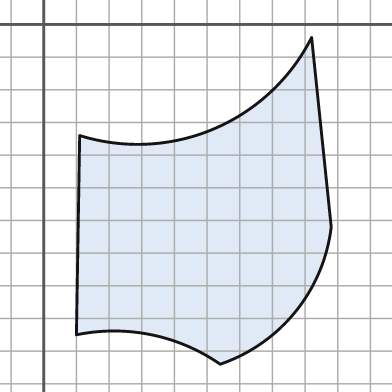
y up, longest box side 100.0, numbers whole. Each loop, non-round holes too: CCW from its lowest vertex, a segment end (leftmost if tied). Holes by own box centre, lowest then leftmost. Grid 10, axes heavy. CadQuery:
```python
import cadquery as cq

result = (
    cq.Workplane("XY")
    .moveTo(54.0, -104.0)
    .threePointArc((77.0, -88.0), (88.0, -62.0))
    .lineTo(82.0, -4.0)
    .threePointArc((52.0, -32.0), (11.0, -34.0))
    .lineTo(10.0, -95.0)
    .threePointArc((33.0, -95.0), (54.0, -104.0))
    .close()
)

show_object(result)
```